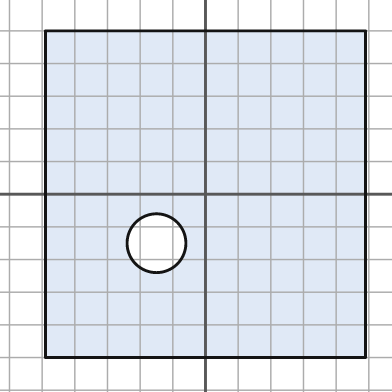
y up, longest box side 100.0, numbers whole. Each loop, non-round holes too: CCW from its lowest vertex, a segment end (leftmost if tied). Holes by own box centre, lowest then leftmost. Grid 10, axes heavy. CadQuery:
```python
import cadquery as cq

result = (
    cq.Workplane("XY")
    .moveTo(-49.0, -50.0)
    .lineTo(49.0, -50.0)
    .lineTo(49.0, 50.0)
    .lineTo(-49.0, 50.0)
    .close()
    .moveTo(-15.0, -15.0)
    .circle(9.0)
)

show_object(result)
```